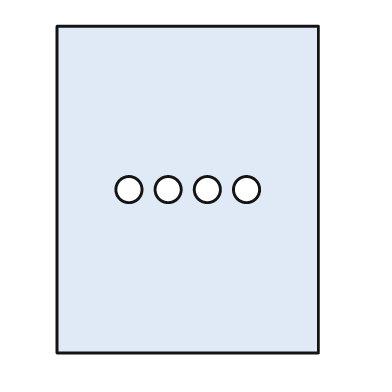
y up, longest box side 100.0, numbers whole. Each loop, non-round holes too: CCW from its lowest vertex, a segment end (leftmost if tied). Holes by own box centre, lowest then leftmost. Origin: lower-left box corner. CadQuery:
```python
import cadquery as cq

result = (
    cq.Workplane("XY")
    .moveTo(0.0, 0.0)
    .lineTo(80.0, 0.0)
    .lineTo(80.0, 100.0)
    .lineTo(0.0, 100.0)
    .close()
    .moveTo(22.0, 50.0)
    .circle(4.0)
    .moveTo(34.0, 50.0)
    .circle(4.0)
    .moveTo(46.0, 50.0)
    .circle(4.0)
    .moveTo(58.0, 50.0)
    .circle(4.0)
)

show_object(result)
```